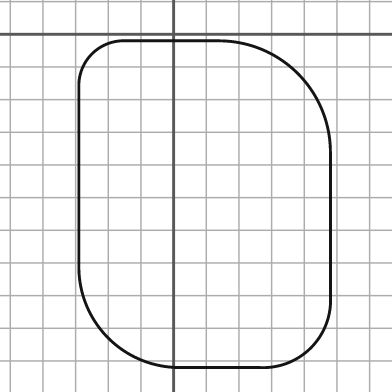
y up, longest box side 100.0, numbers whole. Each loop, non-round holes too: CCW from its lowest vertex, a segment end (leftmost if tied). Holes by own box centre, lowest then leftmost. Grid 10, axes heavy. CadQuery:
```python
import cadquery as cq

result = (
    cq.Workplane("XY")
    .moveTo(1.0, -102.0)
    .lineTo(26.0, -102.0)
    .threePointArc((42.0, -96.0), (48.0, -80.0))
    .lineTo(48.0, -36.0)
    .threePointArc((38.0, -12.0), (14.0, -2.0))
    .lineTo(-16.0, -2.0)
    .threePointArc((-25.0, -6.0), (-29.0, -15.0))
    .lineTo(-29.0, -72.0)
    .threePointArc((-20.0, -93.0), (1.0, -102.0))
    .close()
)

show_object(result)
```